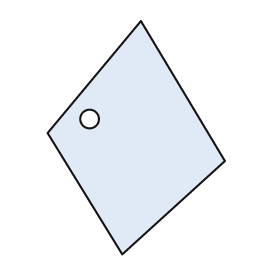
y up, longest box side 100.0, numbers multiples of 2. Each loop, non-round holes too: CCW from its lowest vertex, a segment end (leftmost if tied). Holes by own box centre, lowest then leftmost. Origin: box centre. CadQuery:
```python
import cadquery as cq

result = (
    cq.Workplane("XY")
    .moveTo(-6.0, -50.0)
    .lineTo(38.0, -10.0)
    .lineTo(2.0, 50.0)
    .lineTo(-38.0, 2.0)
    .close()
    .moveTo(-20.0, 8.0)
    .circle(4.0)
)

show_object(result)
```